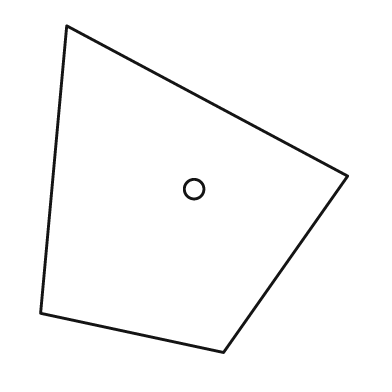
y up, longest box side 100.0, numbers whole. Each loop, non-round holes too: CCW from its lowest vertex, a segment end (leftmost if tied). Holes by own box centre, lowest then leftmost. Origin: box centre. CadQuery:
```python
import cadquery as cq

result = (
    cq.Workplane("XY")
    .moveTo(9.0, -50.0)
    .lineTo(47.0, 4.0)
    .lineTo(-39.0, 50.0)
    .lineTo(-47.0, -38.0)
    .close()
    .moveTo(0.0, 0.0)
    .circle(3.0)
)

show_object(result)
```